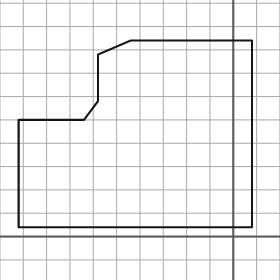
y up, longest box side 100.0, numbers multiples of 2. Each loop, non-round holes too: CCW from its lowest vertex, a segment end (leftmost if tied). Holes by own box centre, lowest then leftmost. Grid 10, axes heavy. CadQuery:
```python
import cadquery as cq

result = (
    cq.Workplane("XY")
    .moveTo(-92.0, 4.0)
    .lineTo(8.0, 4.0)
    .lineTo(8.0, 84.0)
    .lineTo(-44.0, 84.0)
    .lineTo(-58.0, 78.0)
    .lineTo(-58.0, 58.0)
    .lineTo(-64.0, 50.0)
    .lineTo(-92.0, 50.0)
    .close()
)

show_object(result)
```